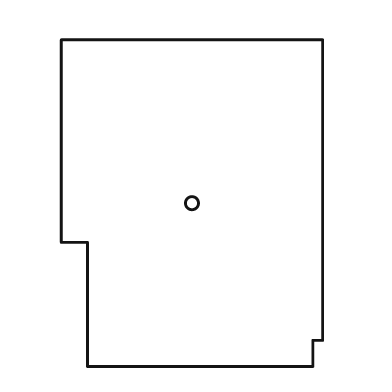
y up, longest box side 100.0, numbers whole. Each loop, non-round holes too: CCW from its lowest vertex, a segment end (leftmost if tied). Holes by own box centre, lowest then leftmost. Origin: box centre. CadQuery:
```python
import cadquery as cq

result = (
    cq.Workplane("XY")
    .moveTo(-32.0, -50.0)
    .lineTo(37.0, -50.0)
    .lineTo(37.0, -42.0)
    .lineTo(40.0, -42.0)
    .lineTo(40.0, 50.0)
    .lineTo(-40.0, 50.0)
    .lineTo(-40.0, -12.0)
    .lineTo(-32.0, -12.0)
    .close()
    .moveTo(0.0, 0.0)
    .circle(2.0)
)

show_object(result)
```